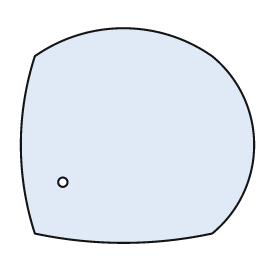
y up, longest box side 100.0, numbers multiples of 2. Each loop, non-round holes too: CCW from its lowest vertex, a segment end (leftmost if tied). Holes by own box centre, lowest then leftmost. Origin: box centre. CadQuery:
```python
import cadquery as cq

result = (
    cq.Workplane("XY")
    .moveTo(-44.0, -42.0)
    .threePointArc((-6.0, -46.0), (32.0, -42.0))
    .threePointArc((50.0, -4.0), (32.0, 34.0))
    .threePointArc((-6.0, 46.0), (-44.0, 34.0))
    .threePointArc((-50.0, -4.0), (-44.0, -42.0))
    .close()
    .moveTo(-32.0, -20.0)
    .circle(2.0)
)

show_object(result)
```